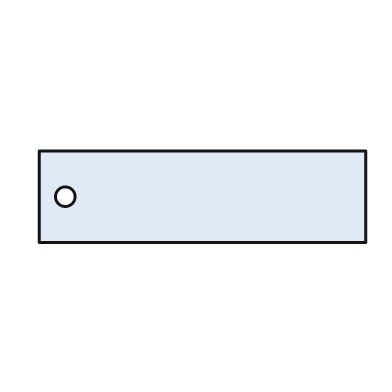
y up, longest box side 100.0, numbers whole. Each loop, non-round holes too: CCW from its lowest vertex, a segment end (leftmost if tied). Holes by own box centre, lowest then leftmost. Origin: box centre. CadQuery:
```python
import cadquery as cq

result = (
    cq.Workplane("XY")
    .moveTo(-50.0, -14.0)
    .lineTo(50.0, -14.0)
    .lineTo(50.0, 14.0)
    .lineTo(-50.0, 14.0)
    .close()
    .moveTo(-42.0, 0.0)
    .circle(3.0)
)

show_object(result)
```